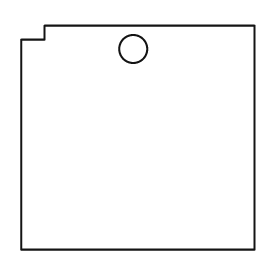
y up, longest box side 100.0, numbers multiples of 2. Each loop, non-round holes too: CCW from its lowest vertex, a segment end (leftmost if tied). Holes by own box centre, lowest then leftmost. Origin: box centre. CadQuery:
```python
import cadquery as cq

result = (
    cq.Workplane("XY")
    .moveTo(-50.0, -48.0)
    .lineTo(50.0, -48.0)
    .lineTo(50.0, 48.0)
    .lineTo(-40.0, 48.0)
    .lineTo(-40.0, 42.0)
    .lineTo(-50.0, 42.0)
    .close()
    .moveTo(-2.0, 38.0)
    .circle(6.0)
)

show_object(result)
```